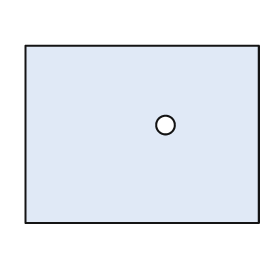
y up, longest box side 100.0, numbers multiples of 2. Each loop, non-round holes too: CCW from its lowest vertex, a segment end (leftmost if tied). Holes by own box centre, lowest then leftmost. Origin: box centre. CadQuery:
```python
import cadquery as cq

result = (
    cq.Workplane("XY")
    .moveTo(-50.0, -38.0)
    .lineTo(50.0, -38.0)
    .lineTo(50.0, 38.0)
    .lineTo(-50.0, 38.0)
    .close()
    .moveTo(10.0, 4.0)
    .circle(4.0)
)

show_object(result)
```